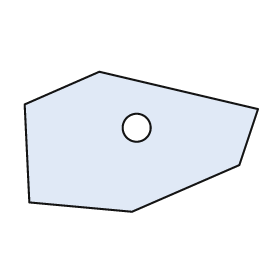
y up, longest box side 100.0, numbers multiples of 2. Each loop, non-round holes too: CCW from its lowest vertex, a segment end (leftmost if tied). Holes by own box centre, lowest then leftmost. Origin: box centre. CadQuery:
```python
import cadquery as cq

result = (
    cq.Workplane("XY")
    .moveTo(-4.0, -30.0)
    .lineTo(42.0, -10.0)
    .lineTo(50.0, 14.0)
    .lineTo(-18.0, 30.0)
    .lineTo(-50.0, 16.0)
    .lineTo(-48.0, -26.0)
    .close()
    .moveTo(-2.0, 6.0)
    .circle(6.0)
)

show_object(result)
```